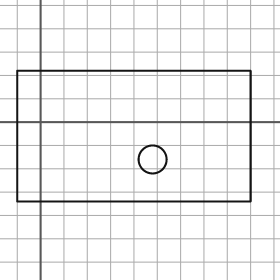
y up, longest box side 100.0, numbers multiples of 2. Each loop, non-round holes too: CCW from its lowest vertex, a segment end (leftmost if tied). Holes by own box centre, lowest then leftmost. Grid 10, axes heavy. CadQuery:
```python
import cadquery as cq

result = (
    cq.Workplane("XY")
    .moveTo(-10.0, -34.0)
    .lineTo(90.0, -34.0)
    .lineTo(90.0, 22.0)
    .lineTo(-10.0, 22.0)
    .close()
    .moveTo(48.0, -16.0)
    .circle(6.0)
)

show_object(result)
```